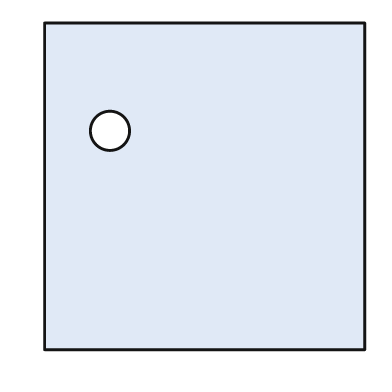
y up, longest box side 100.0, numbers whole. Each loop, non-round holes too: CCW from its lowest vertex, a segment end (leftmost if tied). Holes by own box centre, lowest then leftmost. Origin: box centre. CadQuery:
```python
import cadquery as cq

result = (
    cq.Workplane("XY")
    .moveTo(-49.0, -50.0)
    .lineTo(49.0, -50.0)
    .lineTo(49.0, 50.0)
    .lineTo(-49.0, 50.0)
    .close()
    .moveTo(-29.0, 17.0)
    .circle(6.0)
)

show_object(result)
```